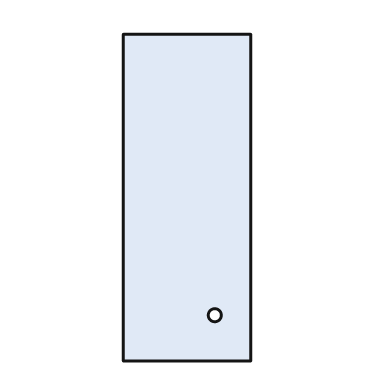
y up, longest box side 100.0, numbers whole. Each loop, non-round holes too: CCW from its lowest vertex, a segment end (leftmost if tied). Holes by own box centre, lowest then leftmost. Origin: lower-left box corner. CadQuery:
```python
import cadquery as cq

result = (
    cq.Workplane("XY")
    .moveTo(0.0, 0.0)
    .lineTo(39.0, 0.0)
    .lineTo(39.0, 100.0)
    .lineTo(0.0, 100.0)
    .close()
    .moveTo(28.0, 14.0)
    .circle(2.0)
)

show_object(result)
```